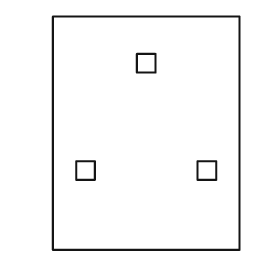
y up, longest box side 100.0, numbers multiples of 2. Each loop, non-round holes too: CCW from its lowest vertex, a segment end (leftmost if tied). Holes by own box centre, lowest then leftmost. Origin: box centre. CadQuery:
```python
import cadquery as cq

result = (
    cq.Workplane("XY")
    .moveTo(-40.0, -50.0)
    .lineTo(40.0, -50.0)
    .lineTo(40.0, 50.0)
    .lineTo(-40.0, 50.0)
    .close()
    .moveTo(-30.0, -20.0)
    .lineTo(-22.0, -20.0)
    .lineTo(-22.0, -12.0)
    .lineTo(-30.0, -12.0)
    .close()
    .moveTo(22.0, -20.0)
    .lineTo(30.0, -20.0)
    .lineTo(30.0, -12.0)
    .lineTo(22.0, -12.0)
    .close()
    .moveTo(-4.0, 26.0)
    .lineTo(4.0, 26.0)
    .lineTo(4.0, 34.0)
    .lineTo(-4.0, 34.0)
    .close()
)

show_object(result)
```